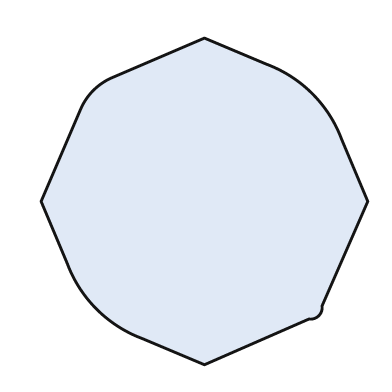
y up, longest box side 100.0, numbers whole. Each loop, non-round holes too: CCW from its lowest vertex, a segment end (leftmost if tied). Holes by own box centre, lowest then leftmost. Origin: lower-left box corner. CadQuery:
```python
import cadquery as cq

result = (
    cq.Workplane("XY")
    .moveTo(50.0, 0.0)
    .lineTo(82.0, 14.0)
    .threePointArc((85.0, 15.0), (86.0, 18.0))
    .lineTo(100.0, 50.0)
    .lineTo(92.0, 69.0)
    .threePointArc((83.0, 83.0), (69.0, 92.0))
    .lineTo(50.0, 100.0)
    .lineTo(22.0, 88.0)
    .threePointArc((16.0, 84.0), (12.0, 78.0))
    .lineTo(0.0, 50.0)
    .lineTo(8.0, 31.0)
    .threePointArc((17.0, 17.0), (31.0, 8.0))
    .close()
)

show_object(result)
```